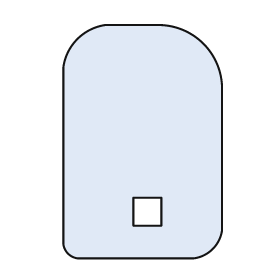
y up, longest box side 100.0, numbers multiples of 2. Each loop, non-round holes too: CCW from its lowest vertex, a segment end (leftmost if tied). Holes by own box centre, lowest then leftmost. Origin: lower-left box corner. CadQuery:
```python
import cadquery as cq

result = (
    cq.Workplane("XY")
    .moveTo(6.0, 0.0)
    .lineTo(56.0, 0.0)
    .threePointArc((64.0, 4.0), (68.0, 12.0))
    .lineTo(68.0, 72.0)
    .threePointArc((60.0, 92.0), (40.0, 100.0))
    .lineTo(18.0, 100.0)
    .threePointArc((6.0, 94.0), (0.0, 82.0))
    .lineTo(0.0, 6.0)
    .threePointArc((2.0, 2.0), (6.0, 0.0))
    .close()
    .moveTo(30.0, 14.0)
    .lineTo(42.0, 14.0)
    .lineTo(42.0, 26.0)
    .lineTo(30.0, 26.0)
    .close()
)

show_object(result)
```